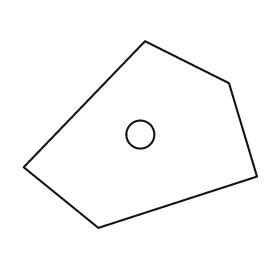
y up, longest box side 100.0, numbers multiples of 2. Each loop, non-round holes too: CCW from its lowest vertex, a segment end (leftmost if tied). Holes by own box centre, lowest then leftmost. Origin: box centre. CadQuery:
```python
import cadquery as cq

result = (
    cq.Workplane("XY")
    .moveTo(-18.0, -40.0)
    .lineTo(50.0, -18.0)
    .lineTo(38.0, 22.0)
    .lineTo(2.0, 40.0)
    .lineTo(-50.0, -14.0)
    .close()
    .moveTo(0.0, 0.0)
    .circle(6.0)
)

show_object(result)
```